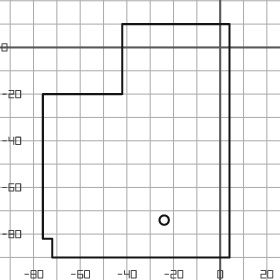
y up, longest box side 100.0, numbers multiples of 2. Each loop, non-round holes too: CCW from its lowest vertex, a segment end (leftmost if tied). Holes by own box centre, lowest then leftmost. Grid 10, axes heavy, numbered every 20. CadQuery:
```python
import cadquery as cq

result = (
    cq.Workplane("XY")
    .moveTo(-72.0, -90.0)
    .lineTo(4.0, -90.0)
    .lineTo(4.0, 10.0)
    .lineTo(-42.0, 10.0)
    .lineTo(-42.0, -20.0)
    .lineTo(-76.0, -20.0)
    .lineTo(-76.0, -82.0)
    .lineTo(-72.0, -82.0)
    .close()
    .moveTo(-24.0, -74.0)
    .circle(2.0)
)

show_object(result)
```